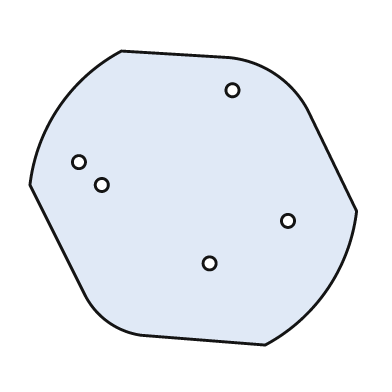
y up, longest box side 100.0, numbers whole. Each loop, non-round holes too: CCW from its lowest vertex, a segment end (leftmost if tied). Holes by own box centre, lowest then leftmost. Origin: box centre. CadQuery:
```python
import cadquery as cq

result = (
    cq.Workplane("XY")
    .moveTo(22.0, -45.0)
    .threePointArc((41.0, -28.0), (50.0, -4.0))
    .lineTo(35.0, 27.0)
    .threePointArc((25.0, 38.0), (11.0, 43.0))
    .lineTo(-22.0, 45.0)
    .threePointArc((-41.0, 28.0), (-50.0, 4.0))
    .lineTo(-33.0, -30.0)
    .threePointArc((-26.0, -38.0), (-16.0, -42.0))
    .close()
    .moveTo(5.0, -20.0)
    .circle(2.0)
    .moveTo(29.0, -7.0)
    .circle(2.0)
    .moveTo(-28.0, 4.0)
    .circle(2.0)
    .moveTo(-35.0, 11.0)
    .circle(2.0)
    .moveTo(12.0, 33.0)
    .circle(2.0)
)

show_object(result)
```